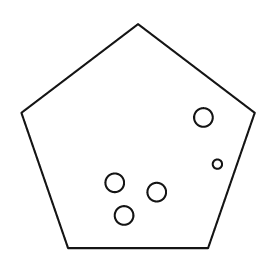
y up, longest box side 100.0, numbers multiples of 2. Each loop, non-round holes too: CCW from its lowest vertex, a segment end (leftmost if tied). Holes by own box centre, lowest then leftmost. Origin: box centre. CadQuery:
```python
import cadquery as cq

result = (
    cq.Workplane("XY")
    .moveTo(-30.0, -48.0)
    .lineTo(30.0, -48.0)
    .lineTo(50.0, 10.0)
    .lineTo(0.0, 48.0)
    .lineTo(-50.0, 10.0)
    .close()
    .moveTo(-6.0, -34.0)
    .circle(4.0)
    .moveTo(8.0, -24.0)
    .circle(4.0)
    .moveTo(-10.0, -20.0)
    .circle(4.0)
    .moveTo(34.0, -12.0)
    .circle(2.0)
    .moveTo(28.0, 8.0)
    .circle(4.0)
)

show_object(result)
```